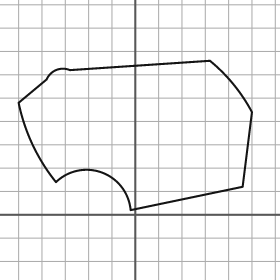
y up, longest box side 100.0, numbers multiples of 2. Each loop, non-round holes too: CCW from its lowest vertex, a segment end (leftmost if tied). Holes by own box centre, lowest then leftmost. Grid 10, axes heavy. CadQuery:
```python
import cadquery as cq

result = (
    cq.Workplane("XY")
    .moveTo(-2.0, 2.0)
    .lineTo(46.0, 12.0)
    .lineTo(50.0, 44.0)
    .threePointArc((42.0, 56.0), (32.0, 66.0))
    .lineTo(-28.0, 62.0)
    .threePointArc((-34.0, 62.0), (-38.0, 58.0))
    .lineTo(-50.0, 48.0)
    .threePointArc((-44.0, 30.0), (-34.0, 14.0))
    .threePointArc((-14.0, 18.0), (-2.0, 2.0))
    .close()
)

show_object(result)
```